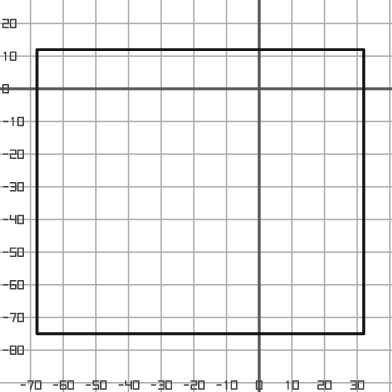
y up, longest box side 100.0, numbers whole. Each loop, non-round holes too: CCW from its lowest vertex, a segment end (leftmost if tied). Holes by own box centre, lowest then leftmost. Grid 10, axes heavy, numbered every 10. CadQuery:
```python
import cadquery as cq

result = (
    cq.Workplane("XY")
    .moveTo(-68.0, -75.0)
    .lineTo(32.0, -75.0)
    .lineTo(32.0, 12.0)
    .lineTo(-68.0, 12.0)
    .close()
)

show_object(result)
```